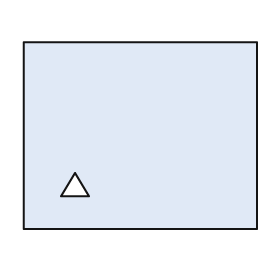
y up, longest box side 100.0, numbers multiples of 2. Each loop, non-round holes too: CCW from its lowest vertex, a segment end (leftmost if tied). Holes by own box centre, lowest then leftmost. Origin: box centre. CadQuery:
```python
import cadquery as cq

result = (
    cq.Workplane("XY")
    .moveTo(-50.0, -40.0)
    .lineTo(50.0, -40.0)
    .lineTo(50.0, 40.0)
    .lineTo(-50.0, 40.0)
    .close()
    .moveTo(-34.0, -26.0)
    .lineTo(-22.0, -26.0)
    .lineTo(-28.0, -16.0)
    .close()
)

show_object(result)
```